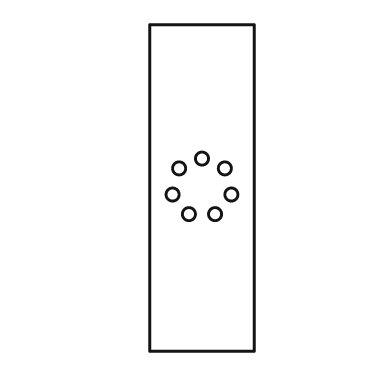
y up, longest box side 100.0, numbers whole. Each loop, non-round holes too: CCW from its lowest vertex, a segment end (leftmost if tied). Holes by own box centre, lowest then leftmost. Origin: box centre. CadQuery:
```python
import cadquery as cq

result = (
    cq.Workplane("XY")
    .moveTo(-16.0, -50.0)
    .lineTo(16.0, -50.0)
    .lineTo(16.0, 50.0)
    .lineTo(-16.0, 50.0)
    .close()
    .moveTo(-4.0, -8.0)
    .circle(2.0)
    .moveTo(4.0, -8.0)
    .circle(2.0)
    .moveTo(-9.0, -2.0)
    .circle(2.0)
    .moveTo(9.0, -2.0)
    .circle(2.0)
    .moveTo(-7.0, 6.0)
    .circle(2.0)
    .moveTo(7.0, 6.0)
    .circle(2.0)
    .moveTo(0.0, 9.0)
    .circle(2.0)
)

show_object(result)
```